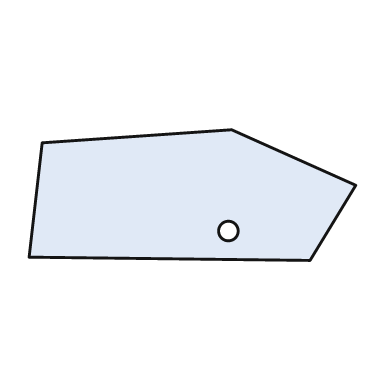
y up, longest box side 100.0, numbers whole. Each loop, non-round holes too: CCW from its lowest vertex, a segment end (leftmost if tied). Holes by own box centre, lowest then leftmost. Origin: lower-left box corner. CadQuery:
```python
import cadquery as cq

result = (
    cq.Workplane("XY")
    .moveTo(86.0, 0.0)
    .lineTo(100.0, 23.0)
    .lineTo(62.0, 40.0)
    .lineTo(4.0, 36.0)
    .lineTo(0.0, 1.0)
    .close()
    .moveTo(61.0, 9.0)
    .circle(3.0)
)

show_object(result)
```